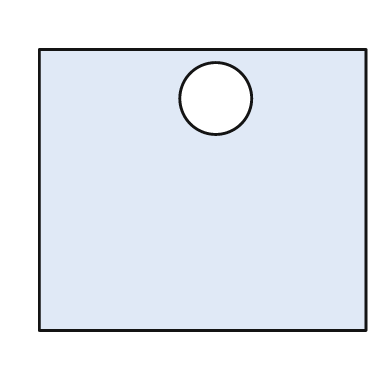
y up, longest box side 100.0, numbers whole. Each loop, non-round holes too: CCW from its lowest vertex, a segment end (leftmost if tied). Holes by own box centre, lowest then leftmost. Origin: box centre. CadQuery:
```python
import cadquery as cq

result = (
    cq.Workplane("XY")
    .moveTo(-50.0, -43.0)
    .lineTo(50.0, -43.0)
    .lineTo(50.0, 43.0)
    .lineTo(-50.0, 43.0)
    .close()
    .moveTo(4.0, 28.0)
    .circle(11.0)
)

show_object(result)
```